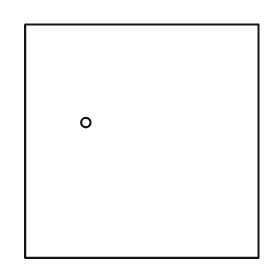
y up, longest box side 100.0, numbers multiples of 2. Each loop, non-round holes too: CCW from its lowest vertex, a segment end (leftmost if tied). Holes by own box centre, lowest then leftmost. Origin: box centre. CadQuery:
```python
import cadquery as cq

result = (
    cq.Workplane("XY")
    .moveTo(-50.0, -50.0)
    .lineTo(50.0, -50.0)
    .lineTo(50.0, 50.0)
    .lineTo(-50.0, 50.0)
    .close()
    .moveTo(-24.0, 8.0)
    .circle(2.0)
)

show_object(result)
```